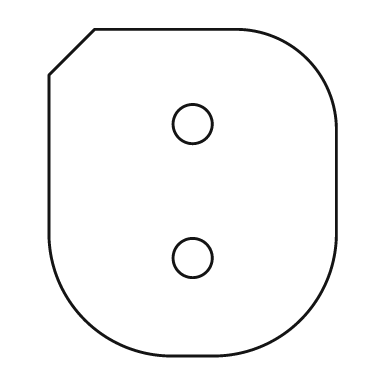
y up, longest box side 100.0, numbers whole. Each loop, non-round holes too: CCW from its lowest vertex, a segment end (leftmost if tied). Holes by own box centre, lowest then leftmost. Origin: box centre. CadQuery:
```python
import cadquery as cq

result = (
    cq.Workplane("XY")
    .moveTo(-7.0, -50.0)
    .lineTo(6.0, -50.0)
    .threePointArc((33.0, -39.0), (44.0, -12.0))
    .lineTo(44.0, 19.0)
    .threePointArc((35.0, 41.0), (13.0, 50.0))
    .lineTo(-30.0, 50.0)
    .lineTo(-44.0, 36.0)
    .lineTo(-44.0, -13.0)
    .threePointArc((-33.0, -39.0), (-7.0, -50.0))
    .close()
    .moveTo(0.0, -20.0)
    .circle(6.0)
    .moveTo(0.0, 21.0)
    .circle(6.0)
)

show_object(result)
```